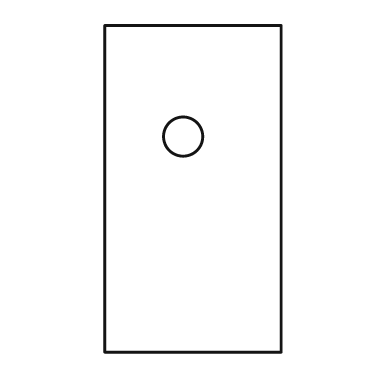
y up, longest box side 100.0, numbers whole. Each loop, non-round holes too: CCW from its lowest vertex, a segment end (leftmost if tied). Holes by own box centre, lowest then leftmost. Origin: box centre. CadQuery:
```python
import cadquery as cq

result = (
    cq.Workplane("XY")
    .moveTo(-27.0, -50.0)
    .lineTo(27.0, -50.0)
    .lineTo(27.0, 50.0)
    .lineTo(-27.0, 50.0)
    .close()
    .moveTo(-3.0, 16.0)
    .circle(6.0)
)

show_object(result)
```